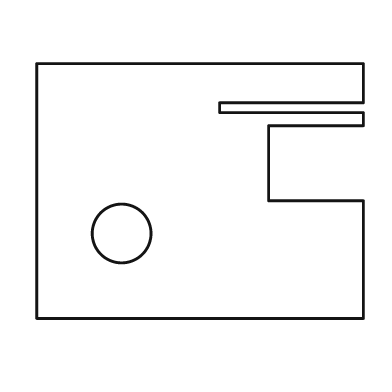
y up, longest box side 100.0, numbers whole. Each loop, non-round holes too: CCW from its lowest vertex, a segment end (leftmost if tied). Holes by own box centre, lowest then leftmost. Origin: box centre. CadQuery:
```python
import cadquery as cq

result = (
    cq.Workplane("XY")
    .moveTo(-50.0, -39.0)
    .lineTo(50.0, -39.0)
    .lineTo(50.0, -3.0)
    .lineTo(21.0, -3.0)
    .lineTo(21.0, 20.0)
    .lineTo(50.0, 20.0)
    .lineTo(50.0, 24.0)
    .lineTo(6.0, 24.0)
    .lineTo(6.0, 27.0)
    .lineTo(50.0, 27.0)
    .lineTo(50.0, 39.0)
    .lineTo(-50.0, 39.0)
    .close()
    .moveTo(-24.0, -13.0)
    .circle(9.0)
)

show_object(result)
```